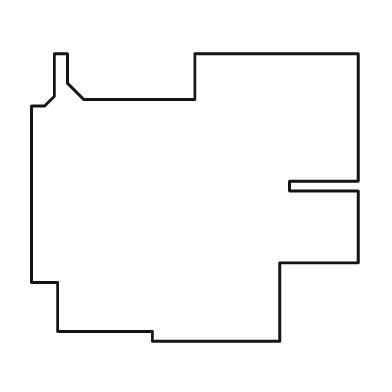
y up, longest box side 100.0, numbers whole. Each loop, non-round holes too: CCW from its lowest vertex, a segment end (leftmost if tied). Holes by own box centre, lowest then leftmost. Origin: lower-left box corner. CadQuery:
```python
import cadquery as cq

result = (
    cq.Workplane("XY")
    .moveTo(37.0, 0.0)
    .lineTo(76.0, 0.0)
    .lineTo(76.0, 24.0)
    .lineTo(100.0, 24.0)
    .lineTo(100.0, 46.0)
    .lineTo(79.0, 46.0)
    .lineTo(79.0, 49.0)
    .lineTo(100.0, 49.0)
    .lineTo(100.0, 88.0)
    .lineTo(50.0, 88.0)
    .lineTo(50.0, 74.0)
    .lineTo(16.0, 74.0)
    .lineTo(11.0, 79.0)
    .lineTo(11.0, 88.0)
    .lineTo(7.0, 88.0)
    .lineTo(7.0, 75.0)
    .lineTo(4.0, 72.0)
    .lineTo(0.0, 72.0)
    .lineTo(0.0, 18.0)
    .lineTo(8.0, 18.0)
    .lineTo(8.0, 3.0)
    .lineTo(37.0, 3.0)
    .close()
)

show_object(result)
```